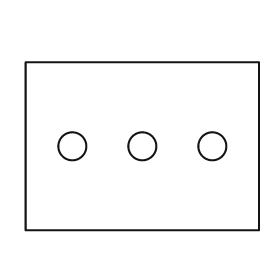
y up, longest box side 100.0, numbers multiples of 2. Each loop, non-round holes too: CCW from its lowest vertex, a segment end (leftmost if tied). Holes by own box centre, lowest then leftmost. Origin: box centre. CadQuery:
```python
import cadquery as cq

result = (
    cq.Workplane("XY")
    .moveTo(-50.0, -36.0)
    .lineTo(50.0, -36.0)
    .lineTo(50.0, 36.0)
    .lineTo(-50.0, 36.0)
    .close()
    .moveTo(-30.0, 0.0)
    .circle(6.0)
    .moveTo(0.0, 0.0)
    .circle(6.0)
    .moveTo(30.0, 0.0)
    .circle(6.0)
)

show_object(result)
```